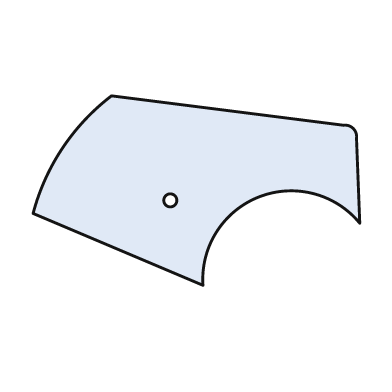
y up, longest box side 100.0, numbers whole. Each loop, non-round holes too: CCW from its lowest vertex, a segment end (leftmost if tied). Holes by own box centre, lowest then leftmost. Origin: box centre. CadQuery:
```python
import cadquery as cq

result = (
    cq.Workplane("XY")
    .moveTo(2.0, -29.0)
    .threePointArc((19.0, -2.0), (50.0, -10.0))
    .lineTo(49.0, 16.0)
    .threePointArc((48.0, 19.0), (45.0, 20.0))
    .lineTo(-26.0, 29.0)
    .threePointArc((-41.0, 13.0), (-50.0, -7.0))
    .close()
    .moveTo(-8.0, -3.0)
    .circle(2.0)
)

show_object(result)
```